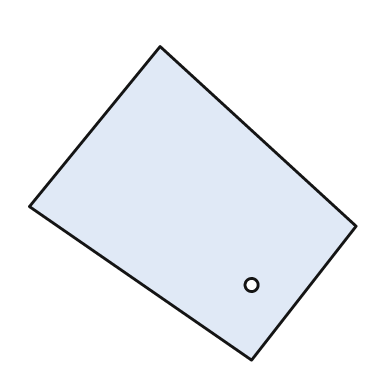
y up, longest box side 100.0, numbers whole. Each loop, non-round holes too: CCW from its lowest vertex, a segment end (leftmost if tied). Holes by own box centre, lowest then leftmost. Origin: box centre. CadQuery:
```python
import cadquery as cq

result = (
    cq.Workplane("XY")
    .moveTo(18.0, -48.0)
    .lineTo(50.0, -7.0)
    .lineTo(-10.0, 48.0)
    .lineTo(-50.0, -1.0)
    .close()
    .moveTo(18.0, -25.0)
    .circle(2.0)
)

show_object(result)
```